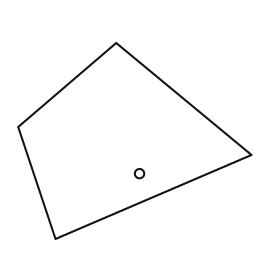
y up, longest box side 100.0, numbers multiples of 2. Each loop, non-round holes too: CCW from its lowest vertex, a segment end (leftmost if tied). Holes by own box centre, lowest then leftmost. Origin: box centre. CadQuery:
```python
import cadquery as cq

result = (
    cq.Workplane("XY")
    .moveTo(-34.0, -42.0)
    .lineTo(50.0, -6.0)
    .lineTo(-8.0, 42.0)
    .lineTo(-50.0, 6.0)
    .close()
    .moveTo(2.0, -14.0)
    .circle(2.0)
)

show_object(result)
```